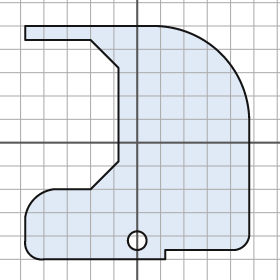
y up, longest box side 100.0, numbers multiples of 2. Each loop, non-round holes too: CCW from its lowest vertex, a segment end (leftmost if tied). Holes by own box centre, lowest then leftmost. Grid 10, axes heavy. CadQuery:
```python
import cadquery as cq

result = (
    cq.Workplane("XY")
    .moveTo(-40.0, -50.0)
    .lineTo(12.0, -50.0)
    .lineTo(12.0, -46.0)
    .lineTo(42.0, -46.0)
    .threePointArc((46.0, -44.0), (48.0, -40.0))
    .lineTo(48.0, 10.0)
    .threePointArc((36.0, 38.0), (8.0, 50.0))
    .lineTo(-48.0, 50.0)
    .lineTo(-48.0, 44.0)
    .lineTo(-20.0, 44.0)
    .lineTo(-8.0, 32.0)
    .lineTo(-8.0, -8.0)
    .lineTo(-20.0, -20.0)
    .lineTo(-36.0, -20.0)
    .threePointArc((-44.0, -24.0), (-48.0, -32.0))
    .lineTo(-48.0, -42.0)
    .threePointArc((-46.0, -48.0), (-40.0, -50.0))
    .close()
    .moveTo(0.0, -42.0)
    .circle(4.0)
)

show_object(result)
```